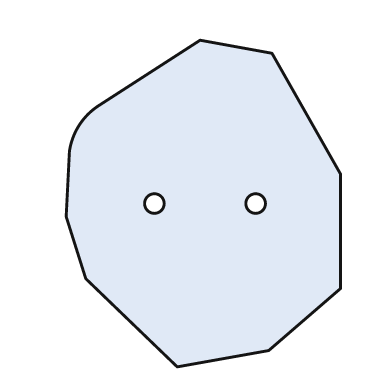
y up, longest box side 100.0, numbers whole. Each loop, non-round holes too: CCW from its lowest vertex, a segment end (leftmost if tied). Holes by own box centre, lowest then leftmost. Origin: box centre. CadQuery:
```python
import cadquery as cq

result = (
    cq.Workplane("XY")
    .moveTo(-8.0, -50.0)
    .lineTo(20.0, -45.0)
    .lineTo(42.0, -26.0)
    .lineTo(42.0, 9.0)
    .lineTo(21.0, 46.0)
    .lineTo(-1.0, 50.0)
    .lineTo(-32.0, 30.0)
    .threePointArc((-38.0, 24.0), (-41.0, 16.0))
    .lineTo(-42.0, -4.0)
    .lineTo(-36.0, -23.0)
    .close()
    .moveTo(-15.0, 0.0)
    .circle(3.0)
    .moveTo(16.0, 0.0)
    .circle(3.0)
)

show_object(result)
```